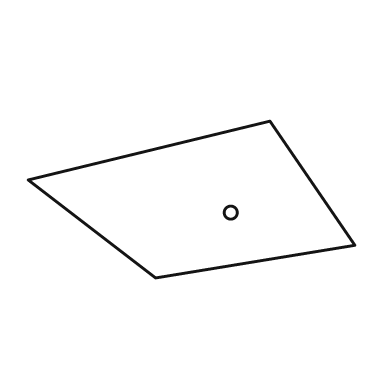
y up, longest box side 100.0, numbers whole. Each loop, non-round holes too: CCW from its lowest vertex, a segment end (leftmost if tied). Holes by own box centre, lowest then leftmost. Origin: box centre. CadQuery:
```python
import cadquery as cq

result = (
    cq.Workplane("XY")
    .moveTo(-11.0, -24.0)
    .lineTo(50.0, -14.0)
    .lineTo(24.0, 24.0)
    .lineTo(-50.0, 6.0)
    .close()
    .moveTo(12.0, -4.0)
    .circle(2.0)
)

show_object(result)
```